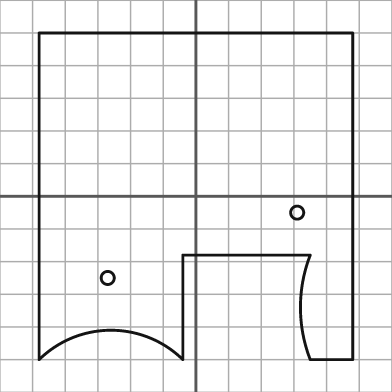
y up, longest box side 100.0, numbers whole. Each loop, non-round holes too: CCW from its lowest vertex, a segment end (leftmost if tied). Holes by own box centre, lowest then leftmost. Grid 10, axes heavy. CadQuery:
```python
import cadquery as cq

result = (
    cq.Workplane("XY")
    .moveTo(-48.0, -50.0)
    .threePointArc((-26.0, -41.0), (-4.0, -50.0))
    .lineTo(-4.0, -18.0)
    .lineTo(35.0, -18.0)
    .threePointArc((32.0, -34.0), (35.0, -50.0))
    .lineTo(48.0, -50.0)
    .lineTo(48.0, 50.0)
    .lineTo(-48.0, 50.0)
    .close()
    .moveTo(-27.0, -25.0)
    .circle(2.0)
    .moveTo(31.0, -5.0)
    .circle(2.0)
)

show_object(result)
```